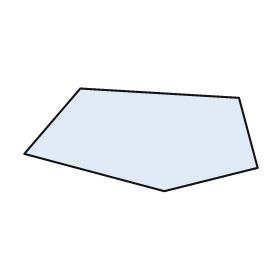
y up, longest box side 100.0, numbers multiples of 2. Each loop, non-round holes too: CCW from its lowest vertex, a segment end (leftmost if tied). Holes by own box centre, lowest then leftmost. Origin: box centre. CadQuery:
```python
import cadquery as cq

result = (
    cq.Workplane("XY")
    .moveTo(10.0, -22.0)
    .lineTo(50.0, -12.0)
    .lineTo(42.0, 18.0)
    .lineTo(-26.0, 22.0)
    .lineTo(-50.0, -6.0)
    .close()
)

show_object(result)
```